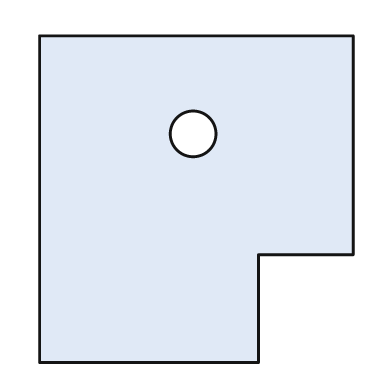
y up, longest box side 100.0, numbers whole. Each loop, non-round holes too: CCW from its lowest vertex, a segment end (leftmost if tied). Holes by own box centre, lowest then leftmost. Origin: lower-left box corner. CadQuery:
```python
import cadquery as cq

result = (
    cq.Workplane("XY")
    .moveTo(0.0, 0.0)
    .lineTo(67.0, 0.0)
    .lineTo(67.0, 33.0)
    .lineTo(96.0, 33.0)
    .lineTo(96.0, 100.0)
    .lineTo(0.0, 100.0)
    .close()
    .moveTo(47.0, 70.0)
    .circle(7.0)
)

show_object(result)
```